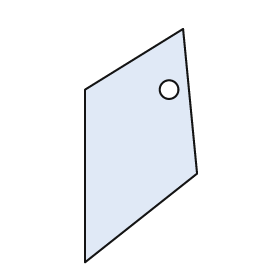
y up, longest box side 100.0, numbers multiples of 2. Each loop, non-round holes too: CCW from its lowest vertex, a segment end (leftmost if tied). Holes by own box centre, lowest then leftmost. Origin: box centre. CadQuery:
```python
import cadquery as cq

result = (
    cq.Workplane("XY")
    .moveTo(-24.0, -50.0)
    .lineTo(24.0, -12.0)
    .lineTo(18.0, 50.0)
    .lineTo(-24.0, 24.0)
    .close()
    .moveTo(12.0, 24.0)
    .circle(4.0)
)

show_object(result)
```